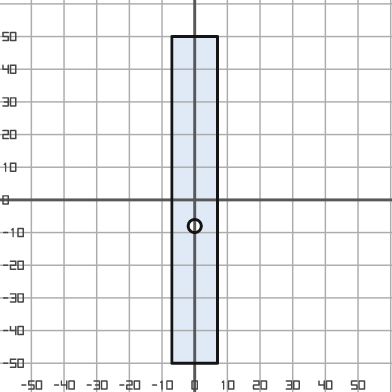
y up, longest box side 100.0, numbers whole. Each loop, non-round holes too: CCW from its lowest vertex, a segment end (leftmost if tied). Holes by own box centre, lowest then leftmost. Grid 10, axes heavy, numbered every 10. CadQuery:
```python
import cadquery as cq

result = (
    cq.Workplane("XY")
    .moveTo(-7.0, -50.0)
    .lineTo(7.0, -50.0)
    .lineTo(7.0, 50.0)
    .lineTo(-7.0, 50.0)
    .close()
    .moveTo(0.0, -8.0)
    .circle(2.0)
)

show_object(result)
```